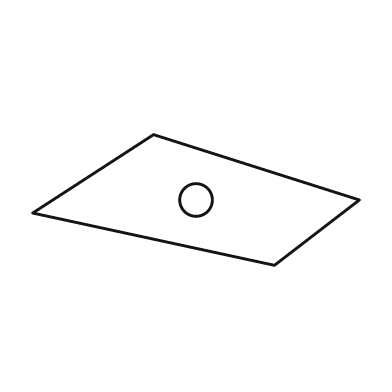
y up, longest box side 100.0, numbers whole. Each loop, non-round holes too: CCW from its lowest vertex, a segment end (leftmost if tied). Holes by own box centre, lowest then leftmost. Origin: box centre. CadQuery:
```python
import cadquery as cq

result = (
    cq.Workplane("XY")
    .moveTo(24.0, -20.0)
    .lineTo(50.0, 0.0)
    .lineTo(-13.0, 20.0)
    .lineTo(-50.0, -4.0)
    .close()
    .moveTo(0.0, 0.0)
    .circle(5.0)
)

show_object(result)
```